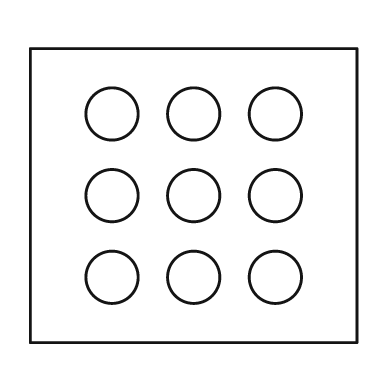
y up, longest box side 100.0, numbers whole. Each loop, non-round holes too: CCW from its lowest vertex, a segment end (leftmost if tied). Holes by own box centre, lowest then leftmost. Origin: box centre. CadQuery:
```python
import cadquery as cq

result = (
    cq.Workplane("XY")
    .moveTo(-50.0, -45.0)
    .lineTo(50.0, -45.0)
    .lineTo(50.0, 45.0)
    .lineTo(-50.0, 45.0)
    .close()
    .moveTo(-25.0, -25.0)
    .circle(8.0)
    .moveTo(0.0, -25.0)
    .circle(8.0)
    .moveTo(25.0, -25.0)
    .circle(8.0)
    .moveTo(-25.0, 0.0)
    .circle(8.0)
    .moveTo(0.0, 0.0)
    .circle(8.0)
    .moveTo(25.0, 0.0)
    .circle(8.0)
    .moveTo(-25.0, 25.0)
    .circle(8.0)
    .moveTo(0.0, 25.0)
    .circle(8.0)
    .moveTo(25.0, 25.0)
    .circle(8.0)
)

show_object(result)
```